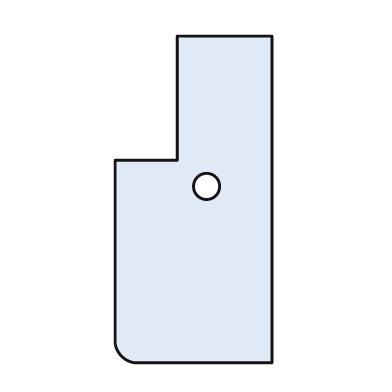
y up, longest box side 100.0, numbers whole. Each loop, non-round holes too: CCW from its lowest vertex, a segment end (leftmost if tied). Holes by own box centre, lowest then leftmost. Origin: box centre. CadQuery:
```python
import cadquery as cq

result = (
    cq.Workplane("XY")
    .moveTo(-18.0, -50.0)
    .lineTo(24.0, -50.0)
    .lineTo(24.0, 50.0)
    .lineTo(-5.0, 50.0)
    .lineTo(-5.0, 12.0)
    .lineTo(-24.0, 12.0)
    .lineTo(-24.0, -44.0)
    .threePointArc((-22.0, -48.0), (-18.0, -50.0))
    .close()
    .moveTo(4.0, 4.0)
    .circle(4.0)
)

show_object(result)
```